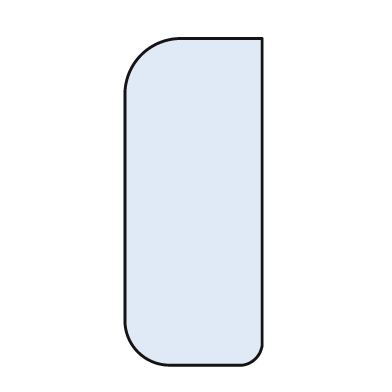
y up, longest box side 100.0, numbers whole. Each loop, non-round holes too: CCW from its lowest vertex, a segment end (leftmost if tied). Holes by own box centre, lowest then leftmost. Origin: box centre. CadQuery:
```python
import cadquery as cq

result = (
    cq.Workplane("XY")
    .moveTo(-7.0, -50.0)
    .lineTo(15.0, -50.0)
    .threePointArc((19.0, -48.0), (21.0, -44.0))
    .lineTo(21.0, 50.0)
    .lineTo(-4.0, 50.0)
    .threePointArc((-16.0, 45.0), (-21.0, 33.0))
    .lineTo(-21.0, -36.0)
    .threePointArc((-17.0, -46.0), (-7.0, -50.0))
    .close()
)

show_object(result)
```